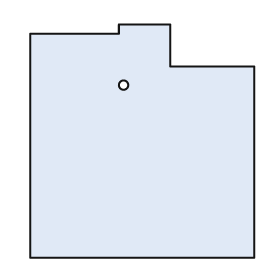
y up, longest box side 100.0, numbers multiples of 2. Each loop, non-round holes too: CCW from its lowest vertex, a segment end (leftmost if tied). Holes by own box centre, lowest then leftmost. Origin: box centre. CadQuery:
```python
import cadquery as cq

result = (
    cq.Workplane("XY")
    .moveTo(-48.0, -50.0)
    .lineTo(48.0, -50.0)
    .lineTo(48.0, 32.0)
    .lineTo(12.0, 32.0)
    .lineTo(12.0, 50.0)
    .lineTo(-10.0, 50.0)
    .lineTo(-10.0, 46.0)
    .lineTo(-48.0, 46.0)
    .close()
    .moveTo(-8.0, 24.0)
    .circle(2.0)
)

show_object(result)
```